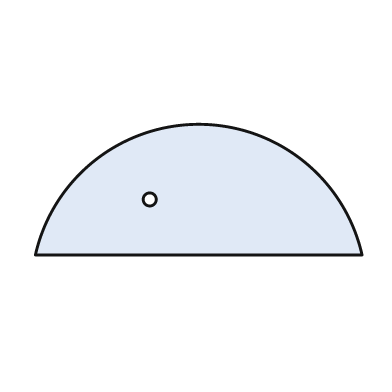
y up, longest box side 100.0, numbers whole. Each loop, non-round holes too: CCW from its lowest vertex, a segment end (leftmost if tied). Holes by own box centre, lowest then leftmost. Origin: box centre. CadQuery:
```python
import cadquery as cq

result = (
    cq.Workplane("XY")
    .moveTo(-50.0, -20.0)
    .lineTo(50.0, -20.0)
    .threePointArc((0.0, 20.0), (-50.0, -20.0))
    .close()
    .moveTo(-15.0, -3.0)
    .circle(2.0)
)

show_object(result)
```